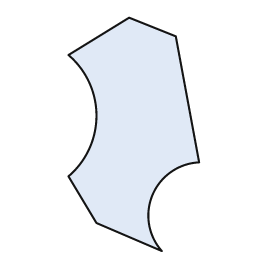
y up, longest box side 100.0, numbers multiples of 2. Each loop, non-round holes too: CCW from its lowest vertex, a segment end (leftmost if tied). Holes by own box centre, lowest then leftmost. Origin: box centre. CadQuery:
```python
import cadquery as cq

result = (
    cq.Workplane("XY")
    .moveTo(12.0, -50.0)
    .threePointArc((8.0, -26.0), (28.0, -12.0))
    .lineTo(18.0, 42.0)
    .lineTo(-2.0, 50.0)
    .lineTo(-28.0, 34.0)
    .threePointArc((-16.0, 8.0), (-28.0, -18.0))
    .lineTo(-16.0, -38.0)
    .close()
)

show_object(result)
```